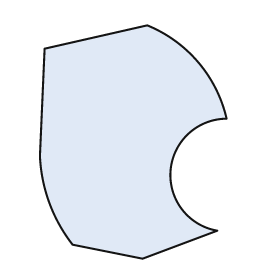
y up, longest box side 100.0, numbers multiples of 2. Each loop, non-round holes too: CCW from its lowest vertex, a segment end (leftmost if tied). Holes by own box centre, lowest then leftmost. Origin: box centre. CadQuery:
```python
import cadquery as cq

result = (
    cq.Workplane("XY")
    .moveTo(4.0, -50.0)
    .lineTo(36.0, -38.0)
    .threePointArc((16.0, -12.0), (40.0, 10.0))
    .threePointArc((28.0, 34.0), (6.0, 50.0))
    .lineTo(-38.0, 40.0)
    .lineTo(-40.0, -6.0)
    .threePointArc((-36.0, -26.0), (-26.0, -44.0))
    .close()
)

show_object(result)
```